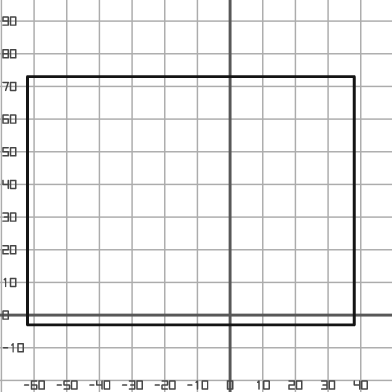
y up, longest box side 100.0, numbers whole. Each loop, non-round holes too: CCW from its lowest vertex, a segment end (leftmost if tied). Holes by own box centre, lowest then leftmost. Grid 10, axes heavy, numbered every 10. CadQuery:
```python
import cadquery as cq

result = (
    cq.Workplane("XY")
    .moveTo(-62.0, -3.0)
    .lineTo(38.0, -3.0)
    .lineTo(38.0, 73.0)
    .lineTo(-62.0, 73.0)
    .close()
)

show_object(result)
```